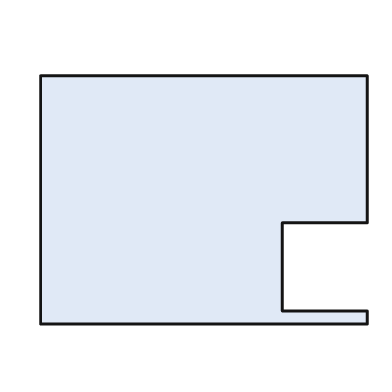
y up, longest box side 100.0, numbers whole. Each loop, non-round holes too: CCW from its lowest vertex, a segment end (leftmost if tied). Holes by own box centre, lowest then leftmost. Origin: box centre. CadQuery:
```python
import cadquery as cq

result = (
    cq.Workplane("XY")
    .moveTo(-50.0, -38.0)
    .lineTo(50.0, -38.0)
    .lineTo(50.0, -34.0)
    .lineTo(24.0, -34.0)
    .lineTo(24.0, -7.0)
    .lineTo(50.0, -7.0)
    .lineTo(50.0, 38.0)
    .lineTo(-50.0, 38.0)
    .close()
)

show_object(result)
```